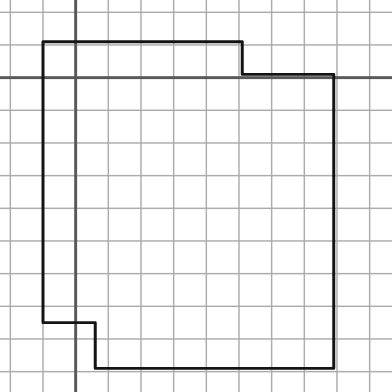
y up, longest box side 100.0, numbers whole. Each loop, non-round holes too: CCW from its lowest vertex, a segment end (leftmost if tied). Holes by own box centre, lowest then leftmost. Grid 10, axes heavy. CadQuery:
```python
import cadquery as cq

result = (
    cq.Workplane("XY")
    .moveTo(6.0, -89.0)
    .lineTo(79.0, -89.0)
    .lineTo(79.0, 1.0)
    .lineTo(51.0, 1.0)
    .lineTo(51.0, 11.0)
    .lineTo(-10.0, 11.0)
    .lineTo(-10.0, -75.0)
    .lineTo(6.0, -75.0)
    .close()
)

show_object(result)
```